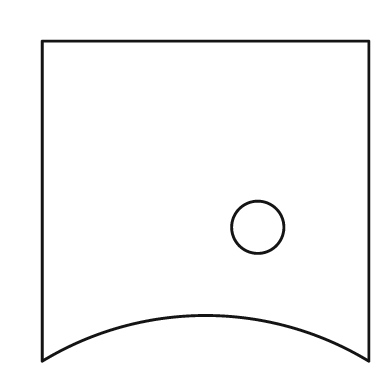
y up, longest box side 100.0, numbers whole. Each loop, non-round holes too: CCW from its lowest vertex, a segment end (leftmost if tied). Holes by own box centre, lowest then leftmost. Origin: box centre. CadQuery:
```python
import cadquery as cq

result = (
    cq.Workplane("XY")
    .moveTo(-50.0, -49.0)
    .threePointArc((0.0, -35.0), (50.0, -49.0))
    .lineTo(50.0, 49.0)
    .lineTo(-50.0, 49.0)
    .close()
    .moveTo(16.0, -8.0)
    .circle(8.0)
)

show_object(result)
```